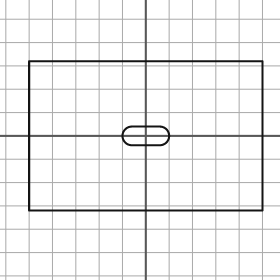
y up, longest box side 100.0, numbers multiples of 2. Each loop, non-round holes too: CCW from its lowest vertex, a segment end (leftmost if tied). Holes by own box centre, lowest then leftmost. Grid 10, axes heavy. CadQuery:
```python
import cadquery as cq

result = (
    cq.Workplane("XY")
    .moveTo(-50.0, -32.0)
    .lineTo(50.0, -32.0)
    .lineTo(50.0, 32.0)
    .lineTo(-50.0, 32.0)
    .close()
    .moveTo(-6.0, -4.0)
    .lineTo(6.0, -4.0)
    .threePointArc((10.0, 0.0), (6.0, 4.0))
    .lineTo(-6.0, 4.0)
    .threePointArc((-10.0, 0.0), (-6.0, -4.0))
    .close()
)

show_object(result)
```